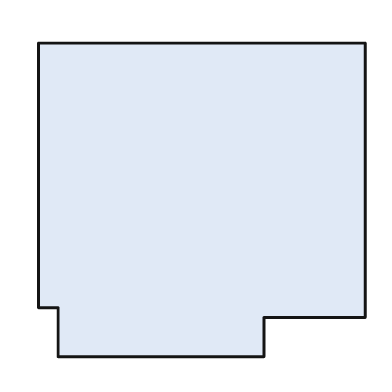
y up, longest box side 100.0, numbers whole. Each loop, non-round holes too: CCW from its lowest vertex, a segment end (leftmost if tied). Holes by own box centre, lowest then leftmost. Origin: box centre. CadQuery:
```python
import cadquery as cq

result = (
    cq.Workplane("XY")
    .moveTo(-44.0, -48.0)
    .lineTo(19.0, -48.0)
    .lineTo(19.0, -36.0)
    .lineTo(50.0, -36.0)
    .lineTo(50.0, 48.0)
    .lineTo(-50.0, 48.0)
    .lineTo(-50.0, -33.0)
    .lineTo(-44.0, -33.0)
    .close()
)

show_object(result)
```